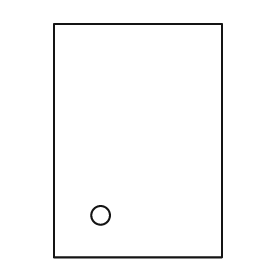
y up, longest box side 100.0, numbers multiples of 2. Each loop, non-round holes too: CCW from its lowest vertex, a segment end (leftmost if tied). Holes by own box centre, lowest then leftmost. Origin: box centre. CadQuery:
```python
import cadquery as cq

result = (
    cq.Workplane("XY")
    .moveTo(-36.0, -50.0)
    .lineTo(36.0, -50.0)
    .lineTo(36.0, 50.0)
    .lineTo(-36.0, 50.0)
    .close()
    .moveTo(-16.0, -32.0)
    .circle(4.0)
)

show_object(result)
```